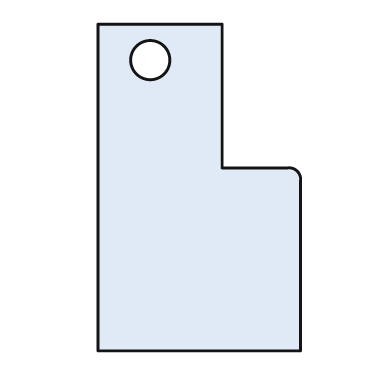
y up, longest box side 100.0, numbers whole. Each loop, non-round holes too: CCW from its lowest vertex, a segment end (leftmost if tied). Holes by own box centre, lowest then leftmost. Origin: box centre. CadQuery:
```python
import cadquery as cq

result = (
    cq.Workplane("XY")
    .moveTo(-31.0, -50.0)
    .lineTo(31.0, -50.0)
    .lineTo(31.0, 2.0)
    .threePointArc((30.0, 5.0), (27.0, 6.0))
    .lineTo(7.0, 6.0)
    .lineTo(7.0, 50.0)
    .lineTo(-31.0, 50.0)
    .close()
    .moveTo(-15.0, 39.0)
    .circle(6.0)
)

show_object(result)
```